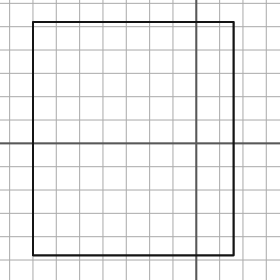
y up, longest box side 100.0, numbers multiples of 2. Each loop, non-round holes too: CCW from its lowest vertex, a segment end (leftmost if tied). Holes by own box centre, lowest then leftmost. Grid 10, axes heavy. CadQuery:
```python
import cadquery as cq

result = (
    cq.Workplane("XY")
    .moveTo(-70.0, -48.0)
    .lineTo(16.0, -48.0)
    .lineTo(16.0, 52.0)
    .lineTo(-70.0, 52.0)
    .close()
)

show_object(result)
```